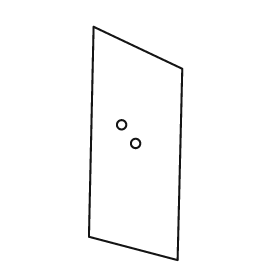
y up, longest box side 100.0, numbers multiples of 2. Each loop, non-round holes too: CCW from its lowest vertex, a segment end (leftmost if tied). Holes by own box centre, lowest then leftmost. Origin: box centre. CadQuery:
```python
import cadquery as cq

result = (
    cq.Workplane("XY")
    .moveTo(18.0, -50.0)
    .lineTo(20.0, 32.0)
    .lineTo(-18.0, 50.0)
    .lineTo(-20.0, -40.0)
    .close()
    .moveTo(0.0, 0.0)
    .circle(2.0)
    .moveTo(-6.0, 8.0)
    .circle(2.0)
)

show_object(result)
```